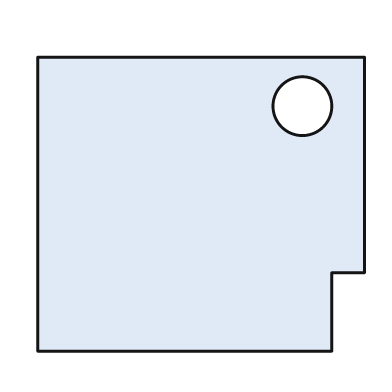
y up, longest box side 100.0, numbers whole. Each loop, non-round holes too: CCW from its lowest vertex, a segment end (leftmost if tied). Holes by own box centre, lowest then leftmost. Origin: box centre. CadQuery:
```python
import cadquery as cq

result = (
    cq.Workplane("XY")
    .moveTo(-50.0, -45.0)
    .lineTo(40.0, -45.0)
    .lineTo(40.0, -21.0)
    .lineTo(50.0, -21.0)
    .lineTo(50.0, 45.0)
    .lineTo(-50.0, 45.0)
    .close()
    .moveTo(31.0, 30.0)
    .circle(9.0)
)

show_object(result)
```